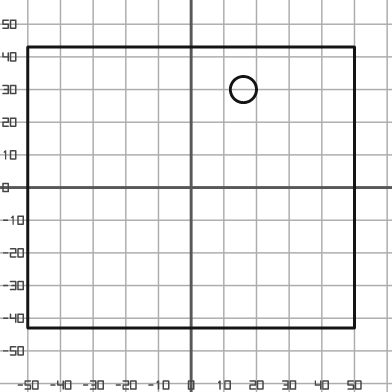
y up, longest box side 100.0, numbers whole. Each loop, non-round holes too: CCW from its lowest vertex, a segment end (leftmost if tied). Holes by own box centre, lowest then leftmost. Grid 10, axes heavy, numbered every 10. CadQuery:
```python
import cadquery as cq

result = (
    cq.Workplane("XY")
    .moveTo(-50.0, -43.0)
    .lineTo(50.0, -43.0)
    .lineTo(50.0, 43.0)
    .lineTo(-50.0, 43.0)
    .close()
    .moveTo(16.0, 30.0)
    .circle(4.0)
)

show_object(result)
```